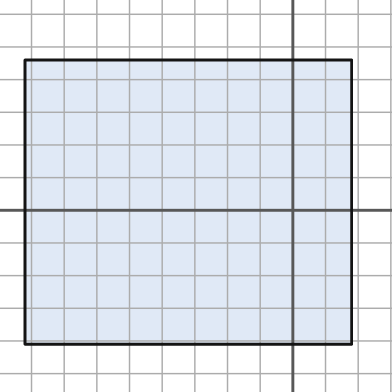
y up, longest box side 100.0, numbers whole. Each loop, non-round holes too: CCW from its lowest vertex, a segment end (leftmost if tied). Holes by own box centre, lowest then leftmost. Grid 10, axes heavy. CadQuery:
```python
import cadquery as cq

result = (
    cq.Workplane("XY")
    .moveTo(-82.0, -41.0)
    .lineTo(18.0, -41.0)
    .lineTo(18.0, 46.0)
    .lineTo(-82.0, 46.0)
    .close()
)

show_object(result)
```